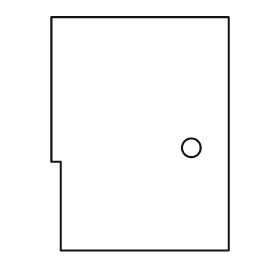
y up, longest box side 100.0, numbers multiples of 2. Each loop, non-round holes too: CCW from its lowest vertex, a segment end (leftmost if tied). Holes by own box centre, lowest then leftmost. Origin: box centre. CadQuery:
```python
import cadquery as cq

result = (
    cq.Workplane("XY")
    .moveTo(-34.0, -50.0)
    .lineTo(38.0, -50.0)
    .lineTo(38.0, 50.0)
    .lineTo(-38.0, 50.0)
    .lineTo(-38.0, -12.0)
    .lineTo(-34.0, -12.0)
    .close()
    .moveTo(22.0, -6.0)
    .circle(4.0)
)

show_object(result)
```